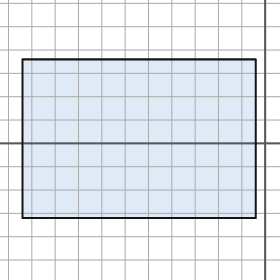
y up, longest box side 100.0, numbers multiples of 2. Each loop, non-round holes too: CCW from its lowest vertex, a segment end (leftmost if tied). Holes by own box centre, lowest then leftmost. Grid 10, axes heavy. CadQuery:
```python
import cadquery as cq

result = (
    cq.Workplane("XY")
    .moveTo(-104.0, -32.0)
    .lineTo(-4.0, -32.0)
    .lineTo(-4.0, 36.0)
    .lineTo(-104.0, 36.0)
    .close()
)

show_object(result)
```